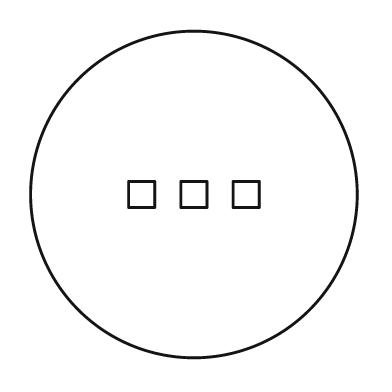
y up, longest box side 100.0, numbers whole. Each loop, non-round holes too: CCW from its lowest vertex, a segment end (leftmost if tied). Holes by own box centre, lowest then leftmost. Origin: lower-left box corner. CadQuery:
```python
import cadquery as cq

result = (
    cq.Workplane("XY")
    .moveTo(50.0, 50.0)
    .circle(50.0)
    .moveTo(30.0, 46.0)
    .lineTo(38.0, 46.0)
    .lineTo(38.0, 54.0)
    .lineTo(30.0, 54.0)
    .close()
    .moveTo(46.0, 46.0)
    .lineTo(54.0, 46.0)
    .lineTo(54.0, 54.0)
    .lineTo(46.0, 54.0)
    .close()
    .moveTo(62.0, 46.0)
    .lineTo(70.0, 46.0)
    .lineTo(70.0, 54.0)
    .lineTo(62.0, 54.0)
    .close()
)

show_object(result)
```